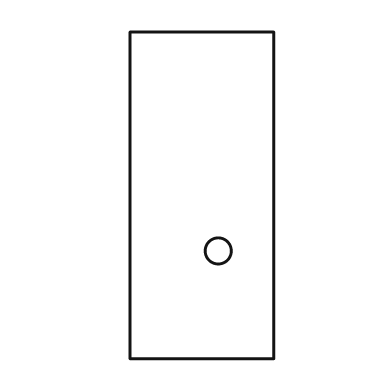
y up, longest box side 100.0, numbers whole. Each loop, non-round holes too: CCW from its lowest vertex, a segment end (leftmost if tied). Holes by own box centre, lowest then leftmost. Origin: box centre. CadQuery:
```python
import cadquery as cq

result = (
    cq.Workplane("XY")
    .moveTo(-22.0, -50.0)
    .lineTo(22.0, -50.0)
    .lineTo(22.0, 50.0)
    .lineTo(-22.0, 50.0)
    .close()
    .moveTo(5.0, -17.0)
    .circle(4.0)
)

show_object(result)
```